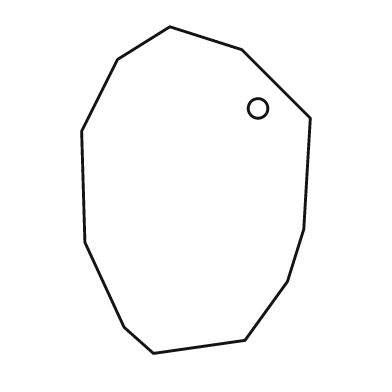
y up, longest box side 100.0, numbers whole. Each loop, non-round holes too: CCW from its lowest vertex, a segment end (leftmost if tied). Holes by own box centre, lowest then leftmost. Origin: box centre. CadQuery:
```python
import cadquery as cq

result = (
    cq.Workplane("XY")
    .moveTo(-13.0, -50.0)
    .lineTo(15.0, -46.0)
    .lineTo(28.0, -28.0)
    .lineTo(33.0, -12.0)
    .lineTo(35.0, 22.0)
    .lineTo(14.0, 43.0)
    .lineTo(-8.0, 50.0)
    .lineTo(-24.0, 40.0)
    .lineTo(-35.0, 18.0)
    .lineTo(-34.0, -16.0)
    .lineTo(-22.0, -42.0)
    .close()
    .moveTo(19.0, 25.0)
    .circle(3.0)
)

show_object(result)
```